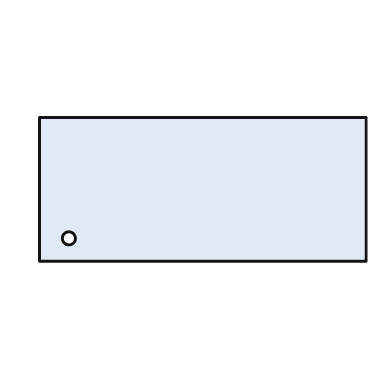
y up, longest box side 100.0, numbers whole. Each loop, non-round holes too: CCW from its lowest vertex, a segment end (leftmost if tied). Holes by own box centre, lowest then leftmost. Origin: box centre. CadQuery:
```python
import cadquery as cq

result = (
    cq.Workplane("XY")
    .moveTo(-50.0, -22.0)
    .lineTo(50.0, -22.0)
    .lineTo(50.0, 22.0)
    .lineTo(-50.0, 22.0)
    .close()
    .moveTo(-41.0, -15.0)
    .circle(2.0)
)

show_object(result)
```